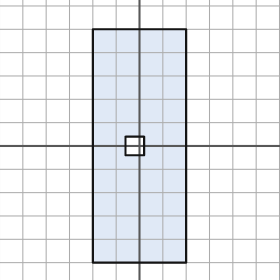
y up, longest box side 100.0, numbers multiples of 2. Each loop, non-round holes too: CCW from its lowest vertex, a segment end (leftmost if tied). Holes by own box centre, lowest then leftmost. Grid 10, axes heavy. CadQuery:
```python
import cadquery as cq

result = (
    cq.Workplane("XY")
    .moveTo(-20.0, -50.0)
    .lineTo(20.0, -50.0)
    .lineTo(20.0, 50.0)
    .lineTo(-20.0, 50.0)
    .close()
    .moveTo(-6.0, -4.0)
    .lineTo(2.0, -4.0)
    .lineTo(2.0, 4.0)
    .lineTo(-6.0, 4.0)
    .close()
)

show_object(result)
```